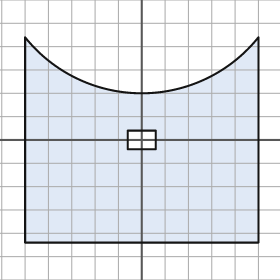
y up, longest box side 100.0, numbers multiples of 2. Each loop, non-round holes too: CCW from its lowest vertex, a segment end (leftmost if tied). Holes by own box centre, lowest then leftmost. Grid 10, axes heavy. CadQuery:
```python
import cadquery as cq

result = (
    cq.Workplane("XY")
    .moveTo(-50.0, -44.0)
    .lineTo(50.0, -44.0)
    .lineTo(50.0, 44.0)
    .threePointArc((0.0, 20.0), (-50.0, 44.0))
    .close()
    .moveTo(-6.0, -4.0)
    .lineTo(6.0, -4.0)
    .lineTo(6.0, 4.0)
    .lineTo(-6.0, 4.0)
    .close()
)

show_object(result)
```